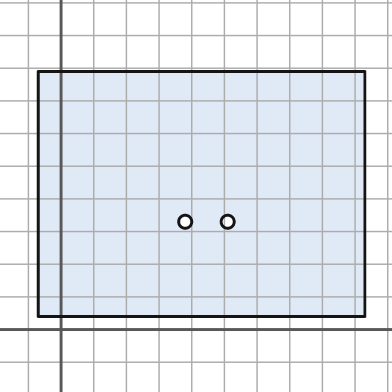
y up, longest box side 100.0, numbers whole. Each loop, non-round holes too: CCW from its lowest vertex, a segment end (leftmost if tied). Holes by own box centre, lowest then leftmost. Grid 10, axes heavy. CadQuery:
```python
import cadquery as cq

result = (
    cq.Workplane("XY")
    .moveTo(-7.0, 4.0)
    .lineTo(93.0, 4.0)
    .lineTo(93.0, 79.0)
    .lineTo(-7.0, 79.0)
    .close()
    .moveTo(38.0, 33.0)
    .circle(2.0)
    .moveTo(51.0, 33.0)
    .circle(2.0)
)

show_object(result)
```